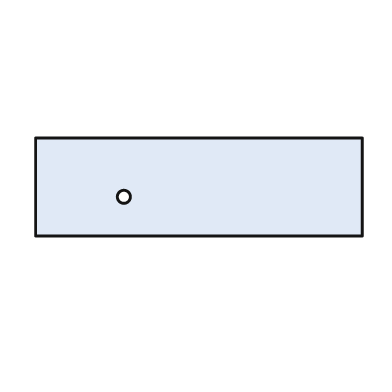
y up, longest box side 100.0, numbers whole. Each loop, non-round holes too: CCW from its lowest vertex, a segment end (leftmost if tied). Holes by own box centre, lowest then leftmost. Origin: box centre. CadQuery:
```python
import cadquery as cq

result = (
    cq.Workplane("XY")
    .moveTo(-50.0, -15.0)
    .lineTo(50.0, -15.0)
    .lineTo(50.0, 15.0)
    .lineTo(-50.0, 15.0)
    .close()
    .moveTo(-23.0, -3.0)
    .circle(2.0)
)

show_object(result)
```